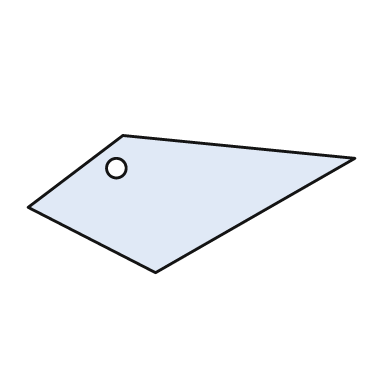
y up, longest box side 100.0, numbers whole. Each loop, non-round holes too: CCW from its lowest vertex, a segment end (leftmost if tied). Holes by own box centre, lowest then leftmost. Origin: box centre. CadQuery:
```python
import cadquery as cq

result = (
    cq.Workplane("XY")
    .moveTo(-11.0, -21.0)
    .lineTo(50.0, 14.0)
    .lineTo(-21.0, 21.0)
    .lineTo(-50.0, -1.0)
    .close()
    .moveTo(-23.0, 11.0)
    .circle(3.0)
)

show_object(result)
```